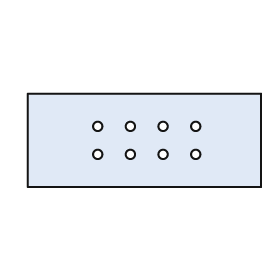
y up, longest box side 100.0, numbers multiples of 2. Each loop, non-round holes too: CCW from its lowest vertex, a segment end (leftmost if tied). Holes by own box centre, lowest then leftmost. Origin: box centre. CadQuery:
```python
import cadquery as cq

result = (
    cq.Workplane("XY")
    .moveTo(-50.0, -20.0)
    .lineTo(50.0, -20.0)
    .lineTo(50.0, 20.0)
    .lineTo(-50.0, 20.0)
    .close()
    .moveTo(-20.0, -6.0)
    .circle(2.0)
    .moveTo(-6.0, -6.0)
    .circle(2.0)
    .moveTo(8.0, -6.0)
    .circle(2.0)
    .moveTo(22.0, -6.0)
    .circle(2.0)
    .moveTo(-20.0, 6.0)
    .circle(2.0)
    .moveTo(-6.0, 6.0)
    .circle(2.0)
    .moveTo(8.0, 6.0)
    .circle(2.0)
    .moveTo(22.0, 6.0)
    .circle(2.0)
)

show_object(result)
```